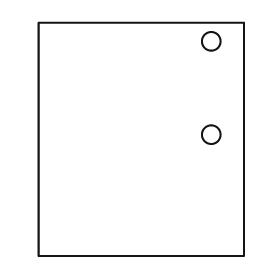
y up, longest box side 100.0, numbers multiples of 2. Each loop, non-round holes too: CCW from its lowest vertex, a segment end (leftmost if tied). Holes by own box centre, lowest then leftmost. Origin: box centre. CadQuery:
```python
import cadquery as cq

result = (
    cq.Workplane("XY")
    .moveTo(-44.0, -50.0)
    .lineTo(44.0, -50.0)
    .lineTo(44.0, 50.0)
    .lineTo(-44.0, 50.0)
    .close()
    .moveTo(30.0, 2.0)
    .circle(4.0)
    .moveTo(30.0, 42.0)
    .circle(4.0)
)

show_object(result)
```